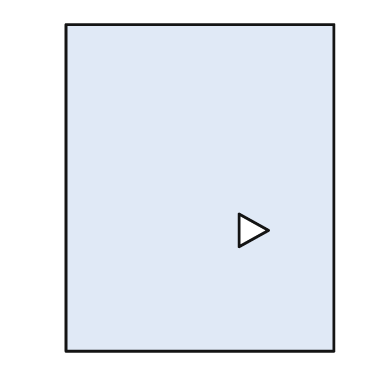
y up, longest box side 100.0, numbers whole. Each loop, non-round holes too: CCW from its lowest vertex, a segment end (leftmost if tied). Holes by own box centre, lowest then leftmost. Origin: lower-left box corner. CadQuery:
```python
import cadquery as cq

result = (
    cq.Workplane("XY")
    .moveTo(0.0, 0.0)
    .lineTo(82.0, 0.0)
    .lineTo(82.0, 100.0)
    .lineTo(0.0, 100.0)
    .close()
    .moveTo(53.0, 32.0)
    .lineTo(62.0, 37.0)
    .lineTo(53.0, 42.0)
    .close()
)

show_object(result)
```